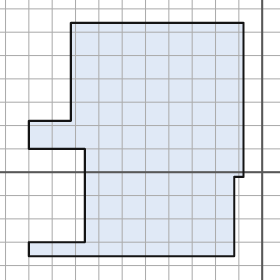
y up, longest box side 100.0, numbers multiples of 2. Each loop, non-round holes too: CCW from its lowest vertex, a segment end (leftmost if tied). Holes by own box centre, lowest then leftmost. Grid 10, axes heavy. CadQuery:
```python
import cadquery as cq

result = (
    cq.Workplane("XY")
    .moveTo(-100.0, -36.0)
    .lineTo(-12.0, -36.0)
    .lineTo(-12.0, -2.0)
    .lineTo(-8.0, -2.0)
    .lineTo(-8.0, 64.0)
    .lineTo(-82.0, 64.0)
    .lineTo(-82.0, 22.0)
    .lineTo(-100.0, 22.0)
    .lineTo(-100.0, 10.0)
    .lineTo(-76.0, 10.0)
    .lineTo(-76.0, -30.0)
    .lineTo(-100.0, -30.0)
    .close()
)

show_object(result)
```